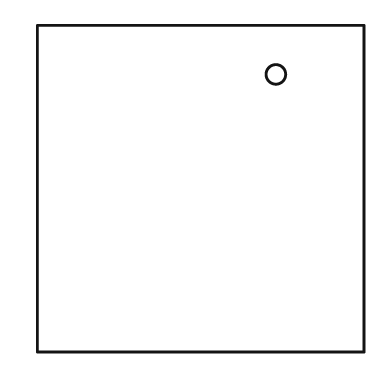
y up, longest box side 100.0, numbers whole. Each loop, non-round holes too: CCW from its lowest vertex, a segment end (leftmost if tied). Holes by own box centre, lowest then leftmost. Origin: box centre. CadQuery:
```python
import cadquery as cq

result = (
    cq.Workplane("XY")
    .moveTo(-50.0, -50.0)
    .lineTo(50.0, -50.0)
    .lineTo(50.0, 50.0)
    .lineTo(-50.0, 50.0)
    .close()
    .moveTo(23.0, 35.0)
    .circle(3.0)
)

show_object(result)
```